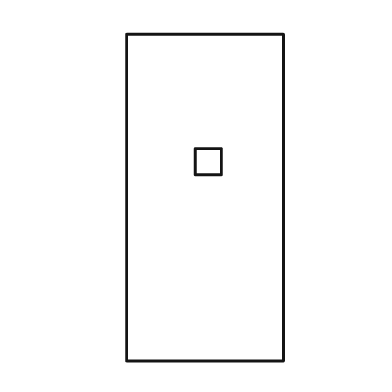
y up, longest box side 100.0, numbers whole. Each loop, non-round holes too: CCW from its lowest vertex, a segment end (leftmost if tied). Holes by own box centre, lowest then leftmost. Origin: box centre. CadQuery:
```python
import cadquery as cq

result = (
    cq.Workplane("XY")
    .moveTo(-24.0, -50.0)
    .lineTo(24.0, -50.0)
    .lineTo(24.0, 50.0)
    .lineTo(-24.0, 50.0)
    .close()
    .moveTo(-3.0, 7.0)
    .lineTo(5.0, 7.0)
    .lineTo(5.0, 15.0)
    .lineTo(-3.0, 15.0)
    .close()
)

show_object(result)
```